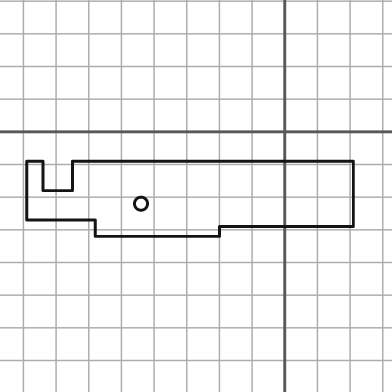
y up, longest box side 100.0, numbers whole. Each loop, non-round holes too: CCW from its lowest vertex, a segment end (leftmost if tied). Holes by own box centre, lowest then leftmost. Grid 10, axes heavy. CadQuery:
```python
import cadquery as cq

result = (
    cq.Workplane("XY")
    .moveTo(-58.0, -32.0)
    .lineTo(-20.0, -32.0)
    .lineTo(-20.0, -29.0)
    .lineTo(21.0, -29.0)
    .lineTo(21.0, -9.0)
    .lineTo(-65.0, -9.0)
    .lineTo(-65.0, -18.0)
    .lineTo(-74.0, -18.0)
    .lineTo(-74.0, -9.0)
    .lineTo(-79.0, -9.0)
    .lineTo(-79.0, -27.0)
    .lineTo(-58.0, -27.0)
    .close()
    .moveTo(-44.0, -22.0)
    .circle(2.0)
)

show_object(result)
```